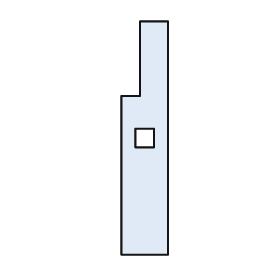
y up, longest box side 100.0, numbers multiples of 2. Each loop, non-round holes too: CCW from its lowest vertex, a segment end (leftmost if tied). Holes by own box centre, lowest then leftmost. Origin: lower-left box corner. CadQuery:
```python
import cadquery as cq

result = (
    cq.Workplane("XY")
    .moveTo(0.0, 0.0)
    .lineTo(20.0, 0.0)
    .lineTo(20.0, 100.0)
    .lineTo(8.0, 100.0)
    .lineTo(8.0, 68.0)
    .lineTo(0.0, 68.0)
    .close()
    .moveTo(6.0, 46.0)
    .lineTo(14.0, 46.0)
    .lineTo(14.0, 54.0)
    .lineTo(6.0, 54.0)
    .close()
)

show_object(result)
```